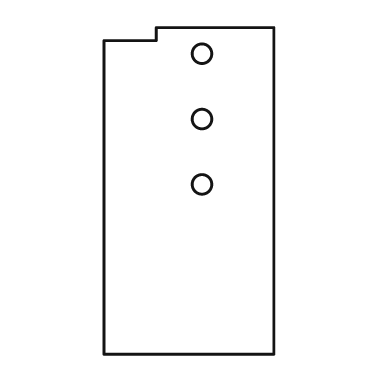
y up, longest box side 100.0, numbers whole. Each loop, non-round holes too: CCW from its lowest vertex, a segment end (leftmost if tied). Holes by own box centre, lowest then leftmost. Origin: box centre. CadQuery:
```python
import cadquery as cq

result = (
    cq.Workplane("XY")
    .moveTo(-26.0, -50.0)
    .lineTo(26.0, -50.0)
    .lineTo(26.0, 50.0)
    .lineTo(-10.0, 50.0)
    .lineTo(-10.0, 46.0)
    .lineTo(-26.0, 46.0)
    .close()
    .moveTo(4.0, 2.0)
    .circle(3.0)
    .moveTo(4.0, 22.0)
    .circle(3.0)
    .moveTo(4.0, 42.0)
    .circle(3.0)
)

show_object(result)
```